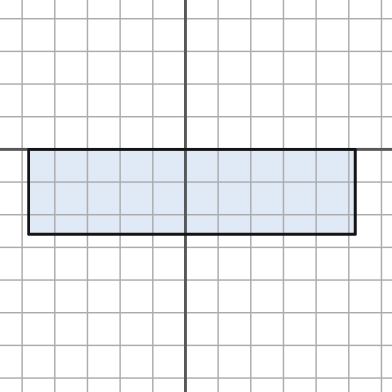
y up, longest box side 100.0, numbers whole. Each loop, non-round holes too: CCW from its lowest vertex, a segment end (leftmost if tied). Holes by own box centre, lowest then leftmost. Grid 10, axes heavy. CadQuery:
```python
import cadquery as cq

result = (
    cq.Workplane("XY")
    .moveTo(-48.0, -26.0)
    .lineTo(52.0, -26.0)
    .lineTo(52.0, 0.0)
    .lineTo(-48.0, 0.0)
    .close()
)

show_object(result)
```